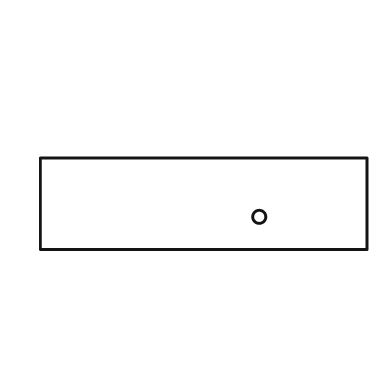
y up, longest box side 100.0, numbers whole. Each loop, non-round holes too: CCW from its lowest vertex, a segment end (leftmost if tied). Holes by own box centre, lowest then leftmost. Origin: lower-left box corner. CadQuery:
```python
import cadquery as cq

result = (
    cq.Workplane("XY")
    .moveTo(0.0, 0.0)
    .lineTo(100.0, 0.0)
    .lineTo(100.0, 28.0)
    .lineTo(0.0, 28.0)
    .close()
    .moveTo(67.0, 10.0)
    .circle(2.0)
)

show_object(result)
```